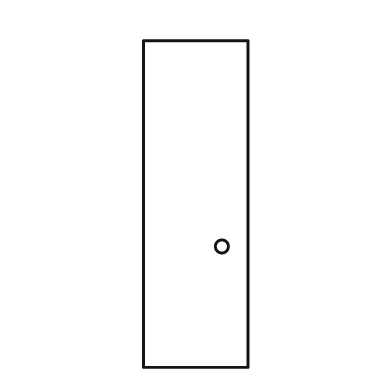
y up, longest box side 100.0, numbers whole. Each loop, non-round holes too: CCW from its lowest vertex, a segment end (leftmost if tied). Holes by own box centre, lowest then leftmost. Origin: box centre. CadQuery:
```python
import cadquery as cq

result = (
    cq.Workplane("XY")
    .moveTo(-16.0, -50.0)
    .lineTo(16.0, -50.0)
    .lineTo(16.0, 50.0)
    .lineTo(-16.0, 50.0)
    .close()
    .moveTo(8.0, -13.0)
    .circle(2.0)
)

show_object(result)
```